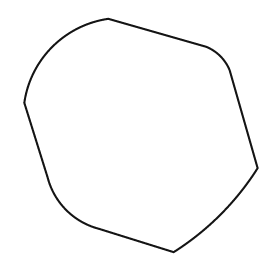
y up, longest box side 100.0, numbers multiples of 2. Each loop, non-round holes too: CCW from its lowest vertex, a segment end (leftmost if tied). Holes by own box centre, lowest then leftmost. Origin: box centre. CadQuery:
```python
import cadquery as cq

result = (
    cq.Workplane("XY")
    .moveTo(14.0, -50.0)
    .threePointArc((34.0, -34.0), (50.0, -14.0))
    .lineTo(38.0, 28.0)
    .threePointArc((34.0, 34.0), (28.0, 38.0))
    .lineTo(-14.0, 50.0)
    .threePointArc((-38.0, 38.0), (-50.0, 14.0))
    .lineTo(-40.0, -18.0)
    .threePointArc((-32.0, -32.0), (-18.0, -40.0))
    .close()
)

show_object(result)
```